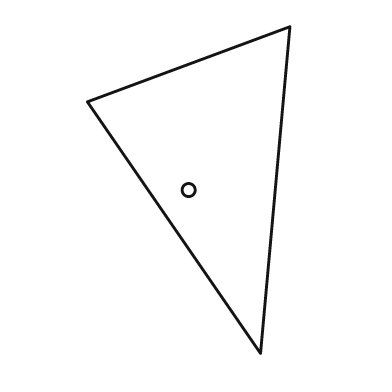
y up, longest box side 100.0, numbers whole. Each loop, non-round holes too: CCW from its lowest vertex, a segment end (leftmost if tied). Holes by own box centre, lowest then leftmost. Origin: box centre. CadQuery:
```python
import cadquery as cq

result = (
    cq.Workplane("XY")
    .moveTo(22.0, -50.0)
    .lineTo(31.0, 50.0)
    .lineTo(-31.0, 27.0)
    .close()
    .moveTo(0.0, 0.0)
    .circle(2.0)
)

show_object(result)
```